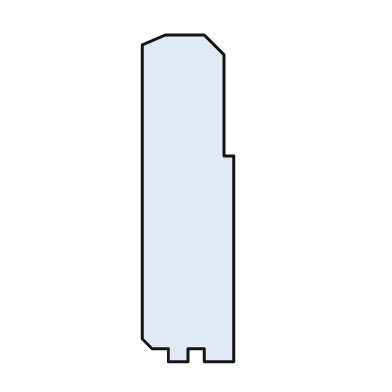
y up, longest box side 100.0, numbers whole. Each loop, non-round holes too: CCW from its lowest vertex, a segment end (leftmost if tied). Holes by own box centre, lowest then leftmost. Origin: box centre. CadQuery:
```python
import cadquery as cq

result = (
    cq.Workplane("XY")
    .moveTo(-6.0, -50.0)
    .lineTo(0.0, -50.0)
    .lineTo(0.0, -46.0)
    .lineTo(5.0, -46.0)
    .lineTo(5.0, -50.0)
    .lineTo(14.0, -50.0)
    .lineTo(14.0, 13.0)
    .lineTo(11.0, 13.0)
    .lineTo(11.0, 44.0)
    .lineTo(5.0, 50.0)
    .lineTo(-7.0, 50.0)
    .lineTo(-14.0, 47.0)
    .lineTo(-14.0, -43.0)
    .lineTo(-11.0, -46.0)
    .lineTo(-6.0, -46.0)
    .close()
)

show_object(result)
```